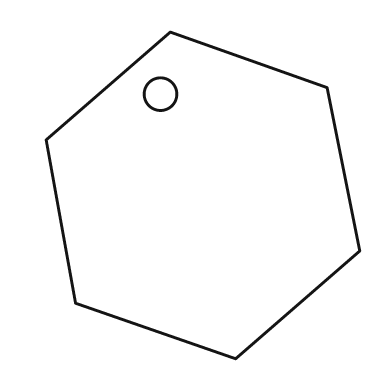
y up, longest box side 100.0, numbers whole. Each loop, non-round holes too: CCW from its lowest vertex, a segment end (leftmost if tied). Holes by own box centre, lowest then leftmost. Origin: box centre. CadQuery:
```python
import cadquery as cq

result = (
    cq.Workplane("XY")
    .moveTo(10.0, -50.0)
    .lineTo(48.0, -17.0)
    .lineTo(38.0, 33.0)
    .lineTo(-10.0, 50.0)
    .lineTo(-48.0, 17.0)
    .lineTo(-39.0, -33.0)
    .close()
    .moveTo(-13.0, 31.0)
    .circle(5.0)
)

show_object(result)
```